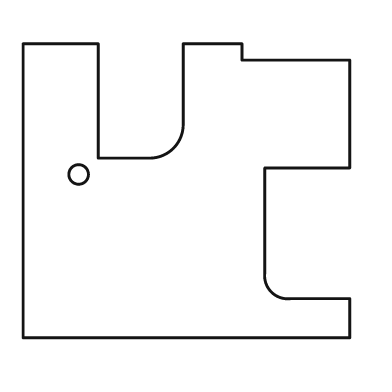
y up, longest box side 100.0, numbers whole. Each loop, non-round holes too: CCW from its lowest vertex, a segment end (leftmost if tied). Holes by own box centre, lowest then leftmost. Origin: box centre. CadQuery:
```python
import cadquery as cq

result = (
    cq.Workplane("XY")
    .moveTo(-50.0, -45.0)
    .lineTo(50.0, -45.0)
    .lineTo(50.0, -33.0)
    .lineTo(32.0, -33.0)
    .threePointArc((26.0, -31.0), (24.0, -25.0))
    .lineTo(24.0, 7.0)
    .lineTo(50.0, 7.0)
    .lineTo(50.0, 40.0)
    .lineTo(17.0, 40.0)
    .lineTo(17.0, 45.0)
    .lineTo(-1.0, 45.0)
    .lineTo(-1.0, 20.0)
    .threePointArc((-4.0, 13.0), (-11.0, 10.0))
    .lineTo(-27.0, 10.0)
    .lineTo(-27.0, 45.0)
    .lineTo(-50.0, 45.0)
    .close()
    .moveTo(-33.0, 5.0)
    .circle(3.0)
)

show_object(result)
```